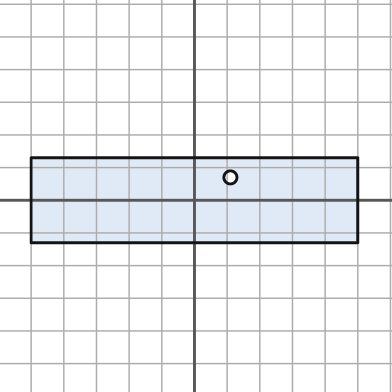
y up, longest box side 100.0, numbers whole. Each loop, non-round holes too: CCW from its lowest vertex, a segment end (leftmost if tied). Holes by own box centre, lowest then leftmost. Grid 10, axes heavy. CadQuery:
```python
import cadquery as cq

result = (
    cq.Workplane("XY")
    .moveTo(-50.0, -13.0)
    .lineTo(50.0, -13.0)
    .lineTo(50.0, 13.0)
    .lineTo(-50.0, 13.0)
    .close()
    .moveTo(11.0, 7.0)
    .circle(2.0)
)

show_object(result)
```